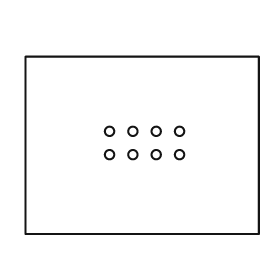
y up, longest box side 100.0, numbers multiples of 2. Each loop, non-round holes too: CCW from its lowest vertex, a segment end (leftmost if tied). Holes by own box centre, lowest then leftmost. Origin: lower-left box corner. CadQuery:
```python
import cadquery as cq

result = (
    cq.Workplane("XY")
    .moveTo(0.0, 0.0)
    .lineTo(100.0, 0.0)
    .lineTo(100.0, 76.0)
    .lineTo(0.0, 76.0)
    .close()
    .moveTo(36.0, 34.0)
    .circle(2.0)
    .moveTo(46.0, 34.0)
    .circle(2.0)
    .moveTo(56.0, 34.0)
    .circle(2.0)
    .moveTo(66.0, 34.0)
    .circle(2.0)
    .moveTo(36.0, 44.0)
    .circle(2.0)
    .moveTo(46.0, 44.0)
    .circle(2.0)
    .moveTo(56.0, 44.0)
    .circle(2.0)
    .moveTo(66.0, 44.0)
    .circle(2.0)
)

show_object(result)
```